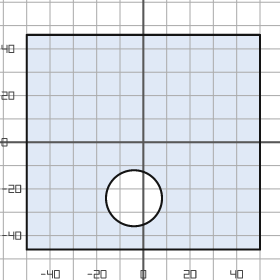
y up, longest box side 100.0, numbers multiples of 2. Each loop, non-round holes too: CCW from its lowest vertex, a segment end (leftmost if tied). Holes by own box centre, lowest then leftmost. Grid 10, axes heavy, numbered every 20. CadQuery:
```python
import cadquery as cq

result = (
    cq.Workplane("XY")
    .moveTo(-50.0, -46.0)
    .lineTo(50.0, -46.0)
    .lineTo(50.0, 46.0)
    .lineTo(-50.0, 46.0)
    .close()
    .moveTo(-4.0, -24.0)
    .circle(12.0)
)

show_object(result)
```